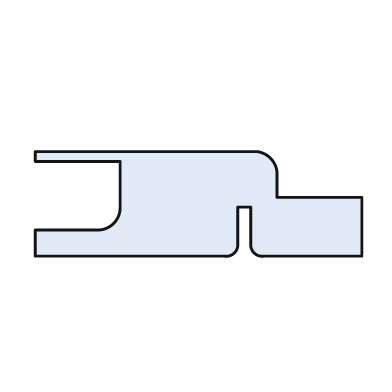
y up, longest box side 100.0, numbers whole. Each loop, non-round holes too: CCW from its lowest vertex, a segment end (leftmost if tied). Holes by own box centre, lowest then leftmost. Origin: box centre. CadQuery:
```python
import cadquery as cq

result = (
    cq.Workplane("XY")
    .moveTo(-50.0, -16.0)
    .lineTo(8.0, -16.0)
    .threePointArc((11.0, -15.0), (12.0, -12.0))
    .lineTo(12.0, -1.0)
    .lineTo(16.0, -1.0)
    .lineTo(16.0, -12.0)
    .threePointArc((17.0, -15.0), (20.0, -16.0))
    .lineTo(50.0, -16.0)
    .lineTo(50.0, 2.0)
    .lineTo(24.0, 2.0)
    .lineTo(24.0, 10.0)
    .threePointArc((22.0, 14.0), (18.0, 16.0))
    .lineTo(-50.0, 16.0)
    .lineTo(-50.0, 13.0)
    .lineTo(-24.0, 13.0)
    .lineTo(-24.0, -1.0)
    .threePointArc((-26.0, -6.0), (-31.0, -8.0))
    .lineTo(-50.0, -8.0)
    .close()
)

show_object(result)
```